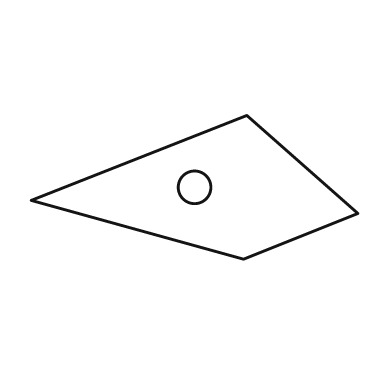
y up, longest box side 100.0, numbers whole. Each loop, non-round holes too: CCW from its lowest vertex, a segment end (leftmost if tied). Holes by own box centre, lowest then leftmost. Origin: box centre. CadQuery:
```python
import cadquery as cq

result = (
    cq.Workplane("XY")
    .moveTo(15.0, -22.0)
    .lineTo(50.0, -8.0)
    .lineTo(16.0, 22.0)
    .lineTo(-50.0, -4.0)
    .close()
    .moveTo(0.0, 0.0)
    .circle(5.0)
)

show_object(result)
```